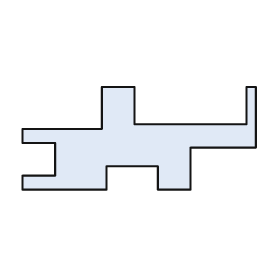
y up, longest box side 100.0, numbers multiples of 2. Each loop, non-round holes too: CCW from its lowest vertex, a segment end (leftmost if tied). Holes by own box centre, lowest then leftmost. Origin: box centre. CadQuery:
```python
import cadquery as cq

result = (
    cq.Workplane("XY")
    .moveTo(-50.0, -22.0)
    .lineTo(-14.0, -22.0)
    .lineTo(-14.0, -12.0)
    .lineTo(8.0, -12.0)
    .lineTo(8.0, -22.0)
    .lineTo(22.0, -22.0)
    .lineTo(22.0, -4.0)
    .lineTo(50.0, -4.0)
    .lineTo(50.0, 22.0)
    .lineTo(46.0, 22.0)
    .lineTo(46.0, 6.0)
    .lineTo(-2.0, 6.0)
    .lineTo(-2.0, 22.0)
    .lineTo(-16.0, 22.0)
    .lineTo(-16.0, 4.0)
    .lineTo(-50.0, 4.0)
    .lineTo(-50.0, -2.0)
    .lineTo(-36.0, -2.0)
    .lineTo(-36.0, -16.0)
    .lineTo(-50.0, -16.0)
    .close()
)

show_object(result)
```